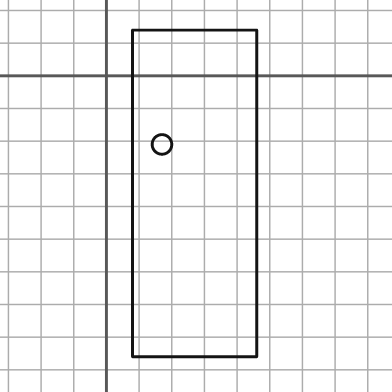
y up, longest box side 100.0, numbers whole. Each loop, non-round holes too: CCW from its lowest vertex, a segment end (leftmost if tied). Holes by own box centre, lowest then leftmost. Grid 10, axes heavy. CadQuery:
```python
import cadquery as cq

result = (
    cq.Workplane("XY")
    .moveTo(8.0, -86.0)
    .lineTo(46.0, -86.0)
    .lineTo(46.0, 14.0)
    .lineTo(8.0, 14.0)
    .close()
    .moveTo(17.0, -21.0)
    .circle(3.0)
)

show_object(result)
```